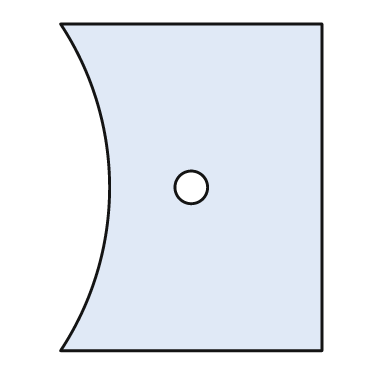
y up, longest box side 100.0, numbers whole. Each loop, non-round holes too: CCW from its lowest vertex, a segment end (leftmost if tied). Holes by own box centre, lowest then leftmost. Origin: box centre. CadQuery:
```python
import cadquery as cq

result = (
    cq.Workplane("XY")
    .moveTo(-40.0, -50.0)
    .lineTo(40.0, -50.0)
    .lineTo(40.0, 50.0)
    .lineTo(-40.0, 50.0)
    .threePointArc((-25.0, 0.0), (-40.0, -50.0))
    .close()
    .moveTo(0.0, 0.0)
    .circle(5.0)
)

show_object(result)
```